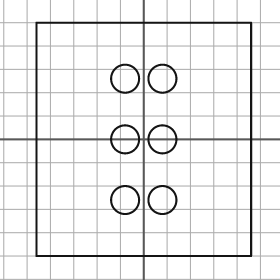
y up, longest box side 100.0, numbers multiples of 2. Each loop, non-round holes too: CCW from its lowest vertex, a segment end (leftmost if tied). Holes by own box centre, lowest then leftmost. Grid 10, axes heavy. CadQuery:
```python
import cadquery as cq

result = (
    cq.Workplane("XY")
    .moveTo(-46.0, -50.0)
    .lineTo(46.0, -50.0)
    .lineTo(46.0, 50.0)
    .lineTo(-46.0, 50.0)
    .close()
    .moveTo(-8.0, -26.0)
    .circle(6.0)
    .moveTo(8.0, -26.0)
    .circle(6.0)
    .moveTo(-8.0, 0.0)
    .circle(6.0)
    .moveTo(8.0, 0.0)
    .circle(6.0)
    .moveTo(-8.0, 26.0)
    .circle(6.0)
    .moveTo(8.0, 26.0)
    .circle(6.0)
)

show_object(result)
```